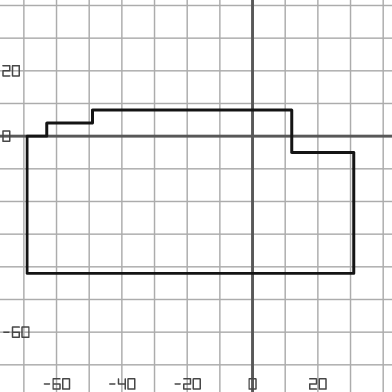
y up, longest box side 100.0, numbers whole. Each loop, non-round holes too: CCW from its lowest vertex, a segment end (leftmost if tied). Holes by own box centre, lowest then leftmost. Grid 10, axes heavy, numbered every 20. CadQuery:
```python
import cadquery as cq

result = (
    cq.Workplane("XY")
    .moveTo(-69.0, -42.0)
    .lineTo(31.0, -42.0)
    .lineTo(31.0, -5.0)
    .lineTo(12.0, -5.0)
    .lineTo(12.0, 8.0)
    .lineTo(-49.0, 8.0)
    .lineTo(-49.0, 4.0)
    .lineTo(-63.0, 4.0)
    .lineTo(-63.0, 0.0)
    .lineTo(-69.0, 0.0)
    .close()
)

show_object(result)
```